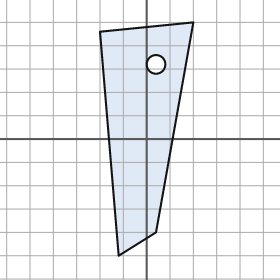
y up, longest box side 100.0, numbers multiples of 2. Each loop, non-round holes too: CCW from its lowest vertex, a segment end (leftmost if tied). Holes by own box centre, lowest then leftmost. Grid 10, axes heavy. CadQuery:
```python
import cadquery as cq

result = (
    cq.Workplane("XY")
    .moveTo(-12.0, -50.0)
    .lineTo(4.0, -40.0)
    .lineTo(20.0, 50.0)
    .lineTo(-20.0, 46.0)
    .close()
    .moveTo(4.0, 32.0)
    .circle(4.0)
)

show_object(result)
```